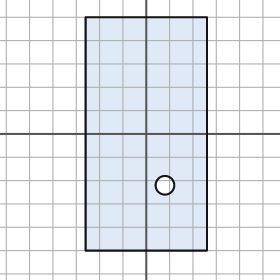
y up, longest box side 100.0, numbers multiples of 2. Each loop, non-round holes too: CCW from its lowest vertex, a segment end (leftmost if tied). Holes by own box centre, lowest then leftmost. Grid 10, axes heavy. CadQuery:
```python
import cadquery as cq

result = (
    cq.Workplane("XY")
    .moveTo(-26.0, -50.0)
    .lineTo(26.0, -50.0)
    .lineTo(26.0, 50.0)
    .lineTo(-26.0, 50.0)
    .close()
    .moveTo(8.0, -22.0)
    .circle(4.0)
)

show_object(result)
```